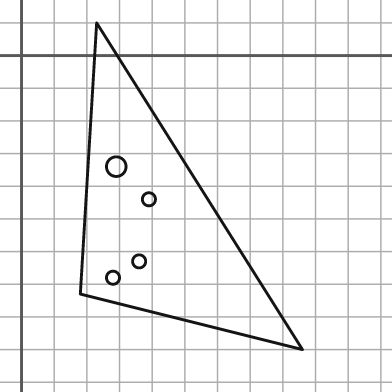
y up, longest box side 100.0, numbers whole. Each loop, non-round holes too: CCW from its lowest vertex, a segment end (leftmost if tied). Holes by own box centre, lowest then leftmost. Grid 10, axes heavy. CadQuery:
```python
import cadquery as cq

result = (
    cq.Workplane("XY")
    .moveTo(86.0, -90.0)
    .lineTo(23.0, 10.0)
    .lineTo(18.0, -73.0)
    .close()
    .moveTo(28.0, -68.0)
    .circle(2.0)
    .moveTo(36.0, -63.0)
    .circle(2.0)
    .moveTo(39.0, -44.0)
    .circle(2.0)
    .moveTo(29.0, -34.0)
    .circle(3.0)
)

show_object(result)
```